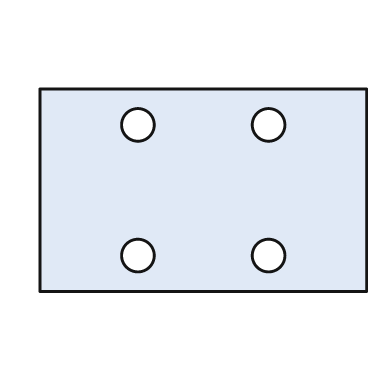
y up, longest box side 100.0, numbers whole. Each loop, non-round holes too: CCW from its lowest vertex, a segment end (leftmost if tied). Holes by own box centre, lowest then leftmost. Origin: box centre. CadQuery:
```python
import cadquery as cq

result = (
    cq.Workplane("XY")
    .moveTo(-50.0, -31.0)
    .lineTo(50.0, -31.0)
    .lineTo(50.0, 31.0)
    .lineTo(-50.0, 31.0)
    .close()
    .moveTo(-20.0, -20.0)
    .circle(5.0)
    .moveTo(20.0, -20.0)
    .circle(5.0)
    .moveTo(-20.0, 20.0)
    .circle(5.0)
    .moveTo(20.0, 20.0)
    .circle(5.0)
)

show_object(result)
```